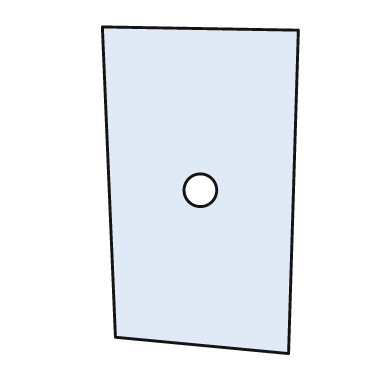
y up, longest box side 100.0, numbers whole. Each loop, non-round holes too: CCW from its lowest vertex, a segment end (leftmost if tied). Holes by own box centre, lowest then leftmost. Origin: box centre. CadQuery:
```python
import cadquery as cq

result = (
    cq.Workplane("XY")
    .moveTo(27.0, -50.0)
    .lineTo(30.0, 49.0)
    .lineTo(-30.0, 50.0)
    .lineTo(-26.0, -45.0)
    .close()
    .moveTo(0.0, 0.0)
    .circle(5.0)
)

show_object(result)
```